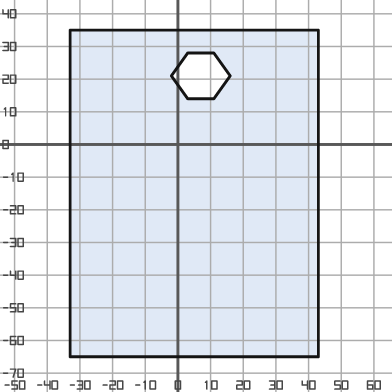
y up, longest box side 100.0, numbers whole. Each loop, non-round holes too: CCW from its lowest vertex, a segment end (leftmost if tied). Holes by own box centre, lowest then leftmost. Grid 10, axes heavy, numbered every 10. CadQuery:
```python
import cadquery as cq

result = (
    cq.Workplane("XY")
    .moveTo(-33.0, -65.0)
    .lineTo(43.0, -65.0)
    .lineTo(43.0, 35.0)
    .lineTo(-33.0, 35.0)
    .close()
    .moveTo(3.0, 14.0)
    .lineTo(11.0, 14.0)
    .lineTo(16.0, 21.0)
    .lineTo(11.0, 28.0)
    .lineTo(3.0, 28.0)
    .lineTo(-2.0, 21.0)
    .close()
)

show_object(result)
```